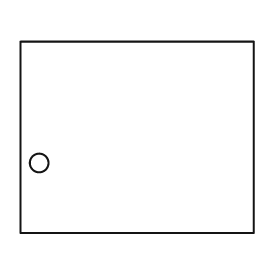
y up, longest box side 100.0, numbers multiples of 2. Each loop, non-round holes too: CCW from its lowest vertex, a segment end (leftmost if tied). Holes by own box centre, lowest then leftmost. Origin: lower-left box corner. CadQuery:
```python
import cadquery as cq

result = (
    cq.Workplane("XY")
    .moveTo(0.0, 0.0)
    .lineTo(100.0, 0.0)
    .lineTo(100.0, 82.0)
    .lineTo(0.0, 82.0)
    .close()
    .moveTo(8.0, 30.0)
    .circle(4.0)
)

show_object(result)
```